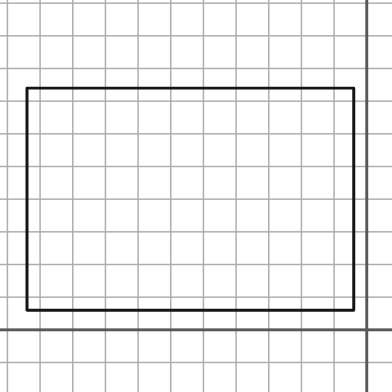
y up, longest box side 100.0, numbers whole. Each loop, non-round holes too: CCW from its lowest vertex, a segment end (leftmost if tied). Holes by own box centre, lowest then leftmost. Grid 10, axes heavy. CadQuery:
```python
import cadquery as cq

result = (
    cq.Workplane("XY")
    .moveTo(-104.0, 6.0)
    .lineTo(-4.0, 6.0)
    .lineTo(-4.0, 74.0)
    .lineTo(-104.0, 74.0)
    .close()
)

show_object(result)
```